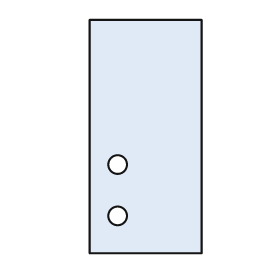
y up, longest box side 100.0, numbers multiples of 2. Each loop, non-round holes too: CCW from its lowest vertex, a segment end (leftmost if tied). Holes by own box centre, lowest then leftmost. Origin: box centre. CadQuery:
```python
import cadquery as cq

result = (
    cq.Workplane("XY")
    .moveTo(-24.0, -50.0)
    .lineTo(24.0, -50.0)
    .lineTo(24.0, 50.0)
    .lineTo(-24.0, 50.0)
    .close()
    .moveTo(-12.0, -34.0)
    .circle(4.0)
    .moveTo(-12.0, -12.0)
    .circle(4.0)
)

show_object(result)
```